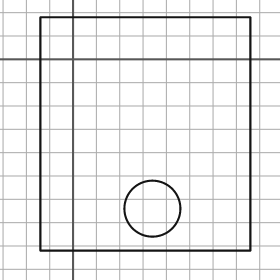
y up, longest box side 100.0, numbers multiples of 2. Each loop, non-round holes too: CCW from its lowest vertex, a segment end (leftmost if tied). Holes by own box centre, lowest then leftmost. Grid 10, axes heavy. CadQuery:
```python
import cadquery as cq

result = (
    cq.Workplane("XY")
    .moveTo(-14.0, -82.0)
    .lineTo(76.0, -82.0)
    .lineTo(76.0, 18.0)
    .lineTo(-14.0, 18.0)
    .close()
    .moveTo(34.0, -64.0)
    .circle(12.0)
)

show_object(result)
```